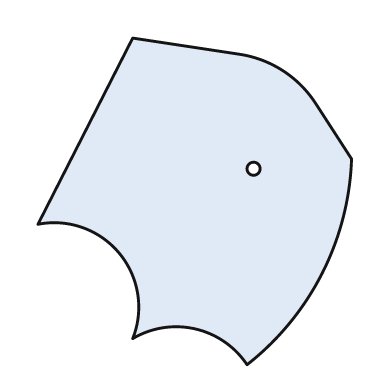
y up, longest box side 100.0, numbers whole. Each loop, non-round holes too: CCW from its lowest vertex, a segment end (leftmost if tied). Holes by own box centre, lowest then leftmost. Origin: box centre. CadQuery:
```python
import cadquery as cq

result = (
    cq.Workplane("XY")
    .moveTo(16.0, -50.0)
    .threePointArc((39.0, -22.0), (48.0, 13.0))
    .lineTo(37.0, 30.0)
    .threePointArc((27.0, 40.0), (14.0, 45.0))
    .lineTo(-19.0, 50.0)
    .lineTo(-48.0, -7.0)
    .threePointArc((-23.0, -16.0), (-19.0, -42.0))
    .threePointArc((0.0, -39.0), (16.0, -50.0))
    .close()
    .moveTo(18.0, 10.0)
    .circle(2.0)
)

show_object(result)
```